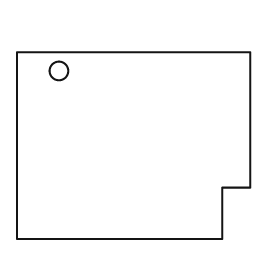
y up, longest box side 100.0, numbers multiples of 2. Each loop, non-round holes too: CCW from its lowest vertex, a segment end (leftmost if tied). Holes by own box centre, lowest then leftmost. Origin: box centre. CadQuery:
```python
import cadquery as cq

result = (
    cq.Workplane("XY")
    .moveTo(-50.0, -40.0)
    .lineTo(38.0, -40.0)
    .lineTo(38.0, -18.0)
    .lineTo(50.0, -18.0)
    .lineTo(50.0, 40.0)
    .lineTo(-50.0, 40.0)
    .close()
    .moveTo(-32.0, 32.0)
    .circle(4.0)
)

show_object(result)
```